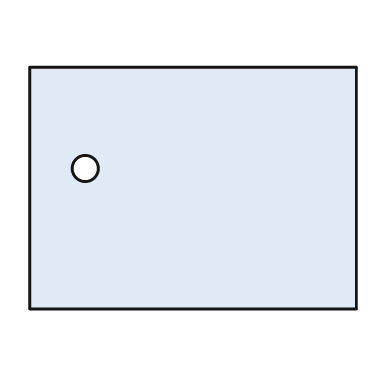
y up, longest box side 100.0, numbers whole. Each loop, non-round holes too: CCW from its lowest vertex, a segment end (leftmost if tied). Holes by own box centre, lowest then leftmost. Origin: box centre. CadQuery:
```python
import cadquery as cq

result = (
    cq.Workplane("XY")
    .moveTo(-50.0, -37.0)
    .lineTo(50.0, -37.0)
    .lineTo(50.0, 37.0)
    .lineTo(-50.0, 37.0)
    .close()
    .moveTo(-33.0, 6.0)
    .circle(4.0)
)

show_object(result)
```